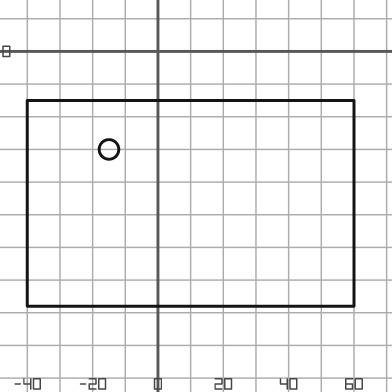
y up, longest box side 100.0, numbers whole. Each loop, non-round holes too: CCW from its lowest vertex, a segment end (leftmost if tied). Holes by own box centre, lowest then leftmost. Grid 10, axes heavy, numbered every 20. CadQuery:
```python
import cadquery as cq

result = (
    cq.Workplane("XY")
    .moveTo(-40.0, -78.0)
    .lineTo(60.0, -78.0)
    .lineTo(60.0, -15.0)
    .lineTo(-40.0, -15.0)
    .close()
    .moveTo(-15.0, -30.0)
    .circle(3.0)
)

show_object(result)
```